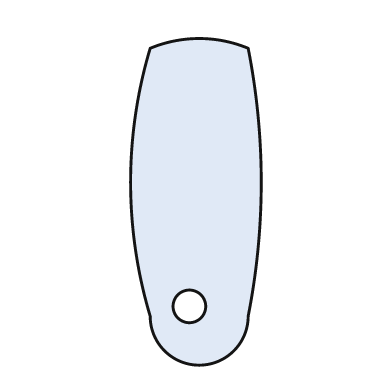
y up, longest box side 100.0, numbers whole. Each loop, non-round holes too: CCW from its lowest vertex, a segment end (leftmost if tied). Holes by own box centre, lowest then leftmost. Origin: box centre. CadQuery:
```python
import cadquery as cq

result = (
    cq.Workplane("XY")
    .moveTo(-14.0, -35.0)
    .threePointArc((1.0, -50.0), (16.0, -35.0))
    .threePointArc((20.0, 6.0), (16.0, 47.0))
    .threePointArc((1.0, 50.0), (-14.0, 47.0))
    .threePointArc((-20.0, 6.0), (-14.0, -35.0))
    .close()
    .moveTo(-2.0, -32.0)
    .circle(5.0)
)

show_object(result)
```